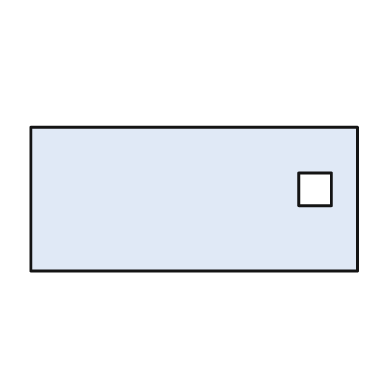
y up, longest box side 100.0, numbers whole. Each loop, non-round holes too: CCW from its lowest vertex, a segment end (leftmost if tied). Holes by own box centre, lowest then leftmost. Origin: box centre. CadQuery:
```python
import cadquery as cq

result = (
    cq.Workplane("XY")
    .moveTo(-50.0, -22.0)
    .lineTo(50.0, -22.0)
    .lineTo(50.0, 22.0)
    .lineTo(-50.0, 22.0)
    .close()
    .moveTo(32.0, -2.0)
    .lineTo(42.0, -2.0)
    .lineTo(42.0, 8.0)
    .lineTo(32.0, 8.0)
    .close()
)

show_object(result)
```